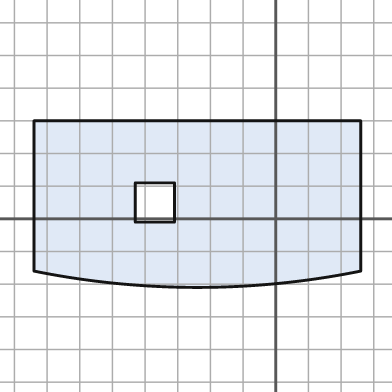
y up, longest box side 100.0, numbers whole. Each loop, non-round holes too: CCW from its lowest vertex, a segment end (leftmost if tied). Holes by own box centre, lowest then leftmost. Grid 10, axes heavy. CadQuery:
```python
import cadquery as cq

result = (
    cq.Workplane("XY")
    .moveTo(-74.0, -16.0)
    .threePointArc((-24.0, -21.0), (26.0, -16.0))
    .lineTo(26.0, 30.0)
    .lineTo(-74.0, 30.0)
    .close()
    .moveTo(-43.0, -1.0)
    .lineTo(-31.0, -1.0)
    .lineTo(-31.0, 11.0)
    .lineTo(-43.0, 11.0)
    .close()
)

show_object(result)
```